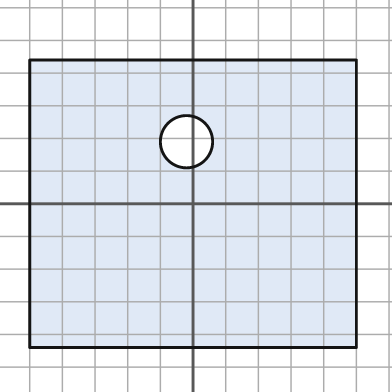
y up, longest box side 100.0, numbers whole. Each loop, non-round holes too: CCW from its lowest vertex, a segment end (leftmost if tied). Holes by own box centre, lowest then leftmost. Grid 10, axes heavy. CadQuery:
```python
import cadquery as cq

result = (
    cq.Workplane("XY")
    .moveTo(-50.0, -44.0)
    .lineTo(50.0, -44.0)
    .lineTo(50.0, 44.0)
    .lineTo(-50.0, 44.0)
    .close()
    .moveTo(-2.0, 19.0)
    .circle(8.0)
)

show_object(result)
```